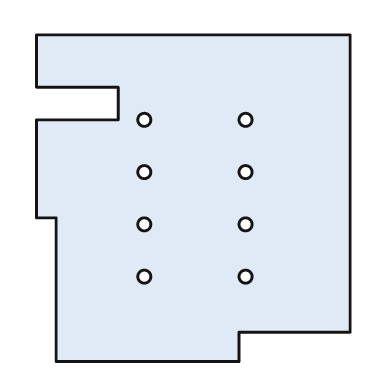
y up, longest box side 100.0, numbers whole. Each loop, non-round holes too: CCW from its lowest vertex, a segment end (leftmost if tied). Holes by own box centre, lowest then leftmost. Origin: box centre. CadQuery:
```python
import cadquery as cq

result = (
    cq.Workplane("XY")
    .moveTo(-42.0, -50.0)
    .lineTo(14.0, -50.0)
    .lineTo(14.0, -41.0)
    .lineTo(48.0, -41.0)
    .lineTo(48.0, 50.0)
    .lineTo(-48.0, 50.0)
    .lineTo(-48.0, 34.0)
    .lineTo(-23.0, 34.0)
    .lineTo(-23.0, 24.0)
    .lineTo(-48.0, 24.0)
    .lineTo(-48.0, -6.0)
    .lineTo(-42.0, -6.0)
    .close()
    .moveTo(-15.0, -24.0)
    .circle(2.0)
    .moveTo(16.0, -24.0)
    .circle(2.0)
    .moveTo(-15.0, -8.0)
    .circle(2.0)
    .moveTo(16.0, -8.0)
    .circle(2.0)
    .moveTo(-15.0, 8.0)
    .circle(2.0)
    .moveTo(16.0, 8.0)
    .circle(2.0)
    .moveTo(-15.0, 24.0)
    .circle(2.0)
    .moveTo(16.0, 24.0)
    .circle(2.0)
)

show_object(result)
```